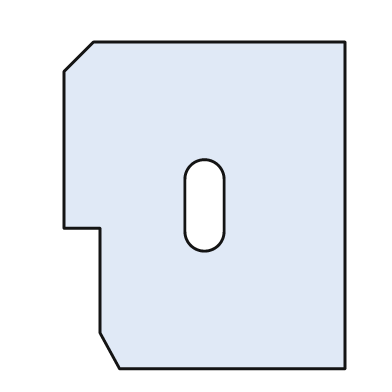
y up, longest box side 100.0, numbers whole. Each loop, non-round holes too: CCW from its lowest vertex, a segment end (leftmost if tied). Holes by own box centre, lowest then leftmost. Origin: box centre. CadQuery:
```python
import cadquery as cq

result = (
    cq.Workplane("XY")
    .moveTo(-26.0, -50.0)
    .lineTo(43.0, -50.0)
    .lineTo(43.0, 50.0)
    .lineTo(-34.0, 50.0)
    .lineTo(-43.0, 41.0)
    .lineTo(-43.0, -7.0)
    .lineTo(-32.0, -7.0)
    .lineTo(-32.0, -39.0)
    .close()
    .moveTo(-6.0, -8.0)
    .threePointArc((0.0, -14.0), (6.0, -8.0))
    .lineTo(6.0, 8.0)
    .threePointArc((0.0, 14.0), (-6.0, 8.0))
    .close()
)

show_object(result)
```